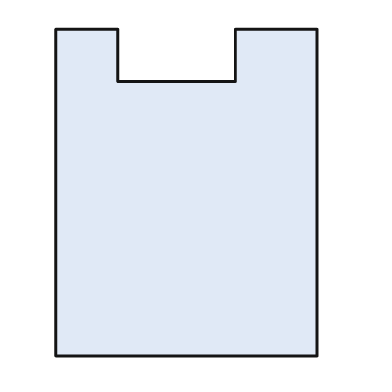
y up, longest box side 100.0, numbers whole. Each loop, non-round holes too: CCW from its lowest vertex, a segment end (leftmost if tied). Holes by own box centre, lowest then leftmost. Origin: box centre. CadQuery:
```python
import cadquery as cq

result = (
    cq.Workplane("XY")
    .moveTo(-40.0, -50.0)
    .lineTo(40.0, -50.0)
    .lineTo(40.0, 50.0)
    .lineTo(15.0, 50.0)
    .lineTo(15.0, 34.0)
    .lineTo(-21.0, 34.0)
    .lineTo(-21.0, 50.0)
    .lineTo(-40.0, 50.0)
    .close()
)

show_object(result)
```